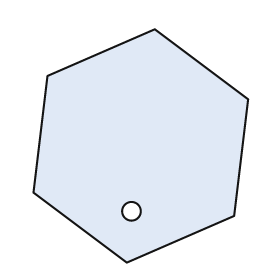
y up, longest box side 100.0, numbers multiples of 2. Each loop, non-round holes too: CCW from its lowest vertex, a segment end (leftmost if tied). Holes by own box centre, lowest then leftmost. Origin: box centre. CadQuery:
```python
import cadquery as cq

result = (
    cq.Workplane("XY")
    .moveTo(-6.0, -50.0)
    .lineTo(40.0, -30.0)
    .lineTo(46.0, 20.0)
    .lineTo(6.0, 50.0)
    .lineTo(-40.0, 30.0)
    .lineTo(-46.0, -20.0)
    .close()
    .moveTo(-4.0, -28.0)
    .circle(4.0)
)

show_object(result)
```